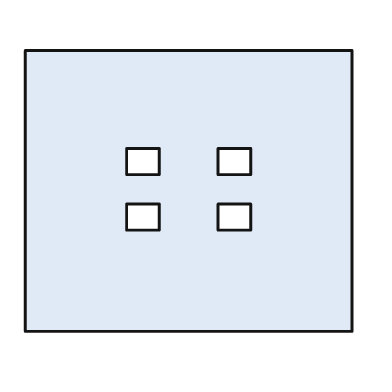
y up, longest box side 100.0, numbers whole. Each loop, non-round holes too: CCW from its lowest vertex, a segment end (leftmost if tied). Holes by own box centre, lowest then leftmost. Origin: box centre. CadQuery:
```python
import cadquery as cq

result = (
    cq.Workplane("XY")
    .moveTo(-50.0, -43.0)
    .lineTo(50.0, -43.0)
    .lineTo(50.0, 43.0)
    .lineTo(-50.0, 43.0)
    .close()
    .moveTo(-19.0, -12.0)
    .lineTo(-9.0, -12.0)
    .lineTo(-9.0, -4.0)
    .lineTo(-19.0, -4.0)
    .close()
    .moveTo(9.0, -12.0)
    .lineTo(19.0, -12.0)
    .lineTo(19.0, -4.0)
    .lineTo(9.0, -4.0)
    .close()
    .moveTo(-19.0, 5.0)
    .lineTo(-9.0, 5.0)
    .lineTo(-9.0, 13.0)
    .lineTo(-19.0, 13.0)
    .close()
    .moveTo(9.0, 5.0)
    .lineTo(19.0, 5.0)
    .lineTo(19.0, 13.0)
    .lineTo(9.0, 13.0)
    .close()
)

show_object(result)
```